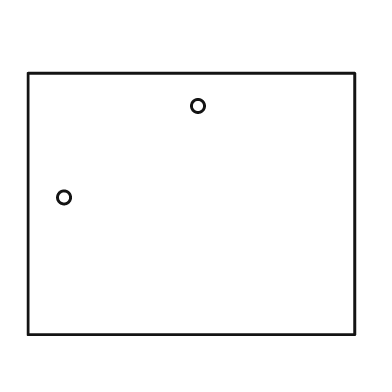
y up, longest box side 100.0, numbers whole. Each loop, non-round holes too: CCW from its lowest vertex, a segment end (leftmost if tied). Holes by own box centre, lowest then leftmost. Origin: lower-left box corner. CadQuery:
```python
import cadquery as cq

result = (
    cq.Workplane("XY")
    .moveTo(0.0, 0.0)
    .lineTo(100.0, 0.0)
    .lineTo(100.0, 80.0)
    .lineTo(0.0, 80.0)
    .close()
    .moveTo(11.0, 42.0)
    .circle(2.0)
    .moveTo(52.0, 70.0)
    .circle(2.0)
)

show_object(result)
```